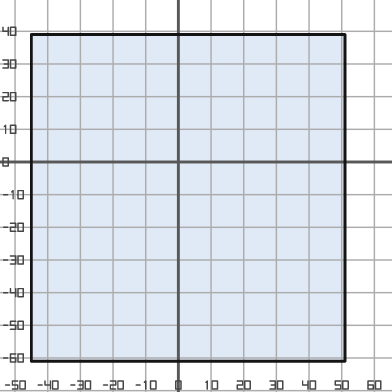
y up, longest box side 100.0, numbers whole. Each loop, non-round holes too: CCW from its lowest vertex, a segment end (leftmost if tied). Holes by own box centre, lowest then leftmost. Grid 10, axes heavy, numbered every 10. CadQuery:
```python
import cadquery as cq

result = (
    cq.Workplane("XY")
    .moveTo(-45.0, -61.0)
    .lineTo(51.0, -61.0)
    .lineTo(51.0, 39.0)
    .lineTo(-45.0, 39.0)
    .close()
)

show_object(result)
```